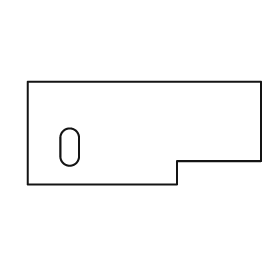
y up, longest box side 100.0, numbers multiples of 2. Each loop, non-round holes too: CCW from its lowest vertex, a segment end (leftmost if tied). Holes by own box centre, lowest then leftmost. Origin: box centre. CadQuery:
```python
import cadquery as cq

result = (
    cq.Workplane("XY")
    .moveTo(-50.0, -22.0)
    .lineTo(14.0, -22.0)
    .lineTo(14.0, -12.0)
    .lineTo(50.0, -12.0)
    .lineTo(50.0, 22.0)
    .lineTo(-50.0, 22.0)
    .close()
    .moveTo(-36.0, -10.0)
    .threePointArc((-32.0, -14.0), (-28.0, -10.0))
    .lineTo(-28.0, -2.0)
    .threePointArc((-32.0, 2.0), (-36.0, -2.0))
    .close()
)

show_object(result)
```